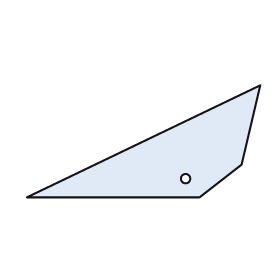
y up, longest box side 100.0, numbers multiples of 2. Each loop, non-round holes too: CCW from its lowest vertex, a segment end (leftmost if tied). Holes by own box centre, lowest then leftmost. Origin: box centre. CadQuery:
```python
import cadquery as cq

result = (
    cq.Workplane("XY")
    .moveTo(-50.0, -24.0)
    .lineTo(24.0, -24.0)
    .lineTo(42.0, -10.0)
    .lineTo(50.0, 24.0)
    .close()
    .moveTo(18.0, -16.0)
    .circle(2.0)
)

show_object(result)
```